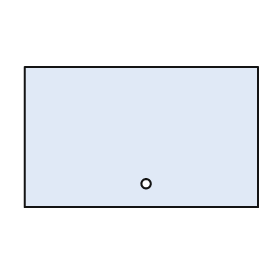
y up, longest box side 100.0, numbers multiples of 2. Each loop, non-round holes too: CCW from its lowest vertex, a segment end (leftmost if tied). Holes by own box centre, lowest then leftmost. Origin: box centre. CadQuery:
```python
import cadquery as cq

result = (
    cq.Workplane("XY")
    .moveTo(-50.0, -30.0)
    .lineTo(50.0, -30.0)
    .lineTo(50.0, 30.0)
    .lineTo(-50.0, 30.0)
    .close()
    .moveTo(2.0, -20.0)
    .circle(2.0)
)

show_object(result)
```